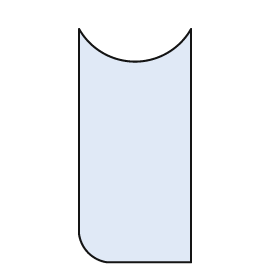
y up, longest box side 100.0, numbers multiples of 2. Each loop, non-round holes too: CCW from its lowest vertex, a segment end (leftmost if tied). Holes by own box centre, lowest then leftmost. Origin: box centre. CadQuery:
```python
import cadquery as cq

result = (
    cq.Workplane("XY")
    .moveTo(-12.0, -50.0)
    .lineTo(24.0, -50.0)
    .lineTo(24.0, 50.0)
    .threePointArc((0.0, 36.0), (-24.0, 50.0))
    .lineTo(-24.0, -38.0)
    .threePointArc((-20.0, -46.0), (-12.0, -50.0))
    .close()
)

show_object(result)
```